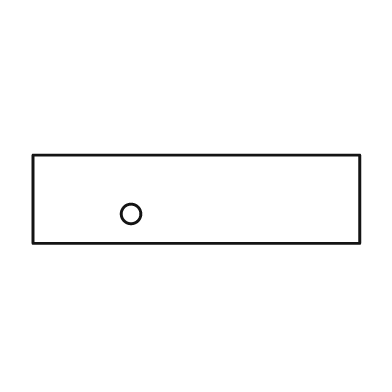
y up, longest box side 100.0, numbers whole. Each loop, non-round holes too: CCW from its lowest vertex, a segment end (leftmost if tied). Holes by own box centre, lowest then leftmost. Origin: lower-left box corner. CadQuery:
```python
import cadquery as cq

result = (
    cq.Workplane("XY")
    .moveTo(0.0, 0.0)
    .lineTo(100.0, 0.0)
    .lineTo(100.0, 27.0)
    .lineTo(0.0, 27.0)
    .close()
    .moveTo(30.0, 9.0)
    .circle(3.0)
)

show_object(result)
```